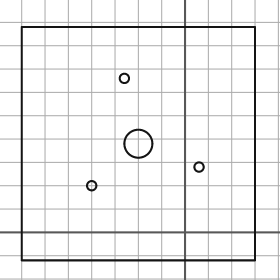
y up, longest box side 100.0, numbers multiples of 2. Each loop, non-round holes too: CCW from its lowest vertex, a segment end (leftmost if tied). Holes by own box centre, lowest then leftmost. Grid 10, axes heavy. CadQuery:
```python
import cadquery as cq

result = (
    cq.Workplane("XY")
    .moveTo(-70.0, -12.0)
    .lineTo(30.0, -12.0)
    .lineTo(30.0, 88.0)
    .lineTo(-70.0, 88.0)
    .close()
    .moveTo(-40.0, 20.0)
    .circle(2.0)
    .moveTo(6.0, 28.0)
    .circle(2.0)
    .moveTo(-20.0, 38.0)
    .circle(6.0)
    .moveTo(-26.0, 66.0)
    .circle(2.0)
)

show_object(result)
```